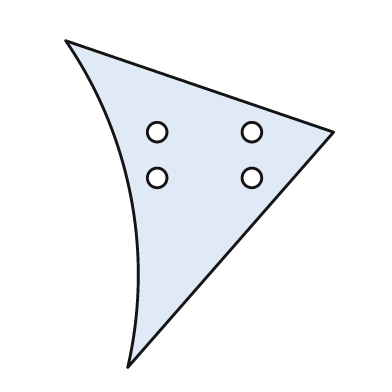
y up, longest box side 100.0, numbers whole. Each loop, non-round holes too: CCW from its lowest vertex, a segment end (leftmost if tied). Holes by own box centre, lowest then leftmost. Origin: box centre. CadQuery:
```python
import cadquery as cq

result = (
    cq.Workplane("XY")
    .moveTo(-22.0, -50.0)
    .lineTo(41.0, 22.0)
    .lineTo(-41.0, 50.0)
    .threePointArc((-21.0, 2.0), (-22.0, -50.0))
    .close()
    .moveTo(-13.0, 8.0)
    .circle(3.0)
    .moveTo(16.0, 8.0)
    .circle(3.0)
    .moveTo(-13.0, 22.0)
    .circle(3.0)
    .moveTo(16.0, 22.0)
    .circle(3.0)
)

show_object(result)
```